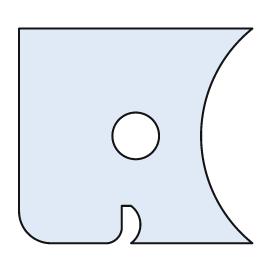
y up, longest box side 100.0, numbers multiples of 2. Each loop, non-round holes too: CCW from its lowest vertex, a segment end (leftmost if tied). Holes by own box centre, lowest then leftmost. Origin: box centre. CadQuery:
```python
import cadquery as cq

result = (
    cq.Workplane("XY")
    .moveTo(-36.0, -46.0)
    .lineTo(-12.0, -46.0)
    .threePointArc((-8.0, -44.0), (-6.0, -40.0))
    .lineTo(-6.0, -30.0)
    .lineTo(-2.0, -30.0)
    .threePointArc((2.0, -38.0), (-2.0, -46.0))
    .lineTo(50.0, -46.0)
    .threePointArc((28.0, 0.0), (50.0, 46.0))
    .lineTo(-50.0, 46.0)
    .lineTo(-50.0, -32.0)
    .threePointArc((-46.0, -42.0), (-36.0, -46.0))
    .close()
    .moveTo(0.0, 0.0)
    .circle(10.0)
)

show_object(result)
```